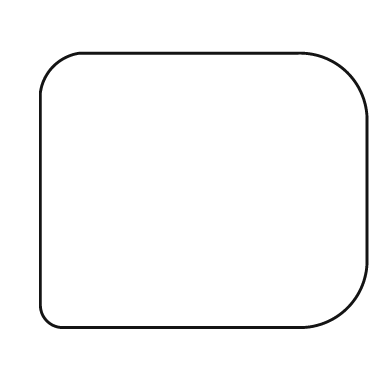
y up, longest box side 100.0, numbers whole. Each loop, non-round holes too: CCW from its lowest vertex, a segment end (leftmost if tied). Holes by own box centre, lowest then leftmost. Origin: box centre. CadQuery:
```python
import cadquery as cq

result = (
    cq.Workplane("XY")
    .moveTo(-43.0, -42.0)
    .lineTo(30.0, -42.0)
    .threePointArc((44.0, -36.0), (50.0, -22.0))
    .lineTo(50.0, 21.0)
    .threePointArc((44.0, 36.0), (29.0, 42.0))
    .lineTo(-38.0, 42.0)
    .threePointArc((-46.0, 38.0), (-50.0, 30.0))
    .lineTo(-50.0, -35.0)
    .threePointArc((-48.0, -40.0), (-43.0, -42.0))
    .close()
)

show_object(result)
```